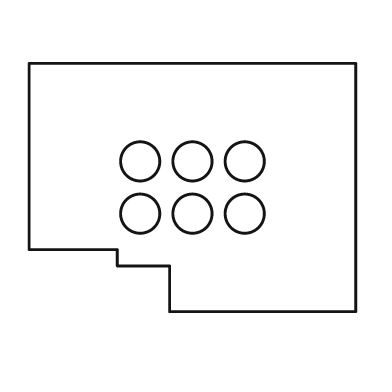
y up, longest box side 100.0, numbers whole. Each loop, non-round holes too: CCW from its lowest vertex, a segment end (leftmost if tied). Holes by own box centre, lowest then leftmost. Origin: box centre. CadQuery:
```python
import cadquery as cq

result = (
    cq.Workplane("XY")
    .moveTo(-7.0, -38.0)
    .lineTo(50.0, -38.0)
    .lineTo(50.0, 38.0)
    .lineTo(-50.0, 38.0)
    .lineTo(-50.0, -19.0)
    .lineTo(-23.0, -19.0)
    .lineTo(-23.0, -24.0)
    .lineTo(-7.0, -24.0)
    .close()
    .moveTo(-16.0, -8.0)
    .circle(6.0)
    .moveTo(0.0, -8.0)
    .circle(6.0)
    .moveTo(16.0, -8.0)
    .circle(6.0)
    .moveTo(-16.0, 8.0)
    .circle(6.0)
    .moveTo(0.0, 8.0)
    .circle(6.0)
    .moveTo(16.0, 8.0)
    .circle(6.0)
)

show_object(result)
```